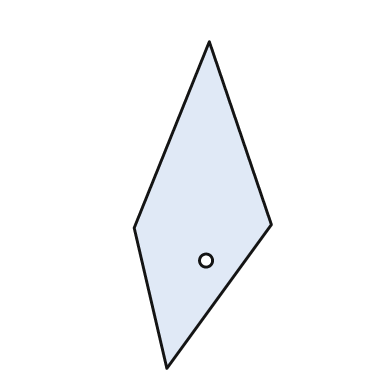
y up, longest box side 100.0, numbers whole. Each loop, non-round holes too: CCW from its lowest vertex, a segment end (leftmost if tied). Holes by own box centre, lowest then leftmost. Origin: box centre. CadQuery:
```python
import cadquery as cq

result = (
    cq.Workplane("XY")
    .moveTo(-11.0, -50.0)
    .lineTo(21.0, -6.0)
    .lineTo(2.0, 50.0)
    .lineTo(-21.0, -7.0)
    .close()
    .moveTo(1.0, -17.0)
    .circle(2.0)
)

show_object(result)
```